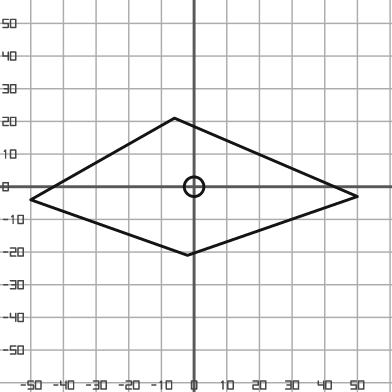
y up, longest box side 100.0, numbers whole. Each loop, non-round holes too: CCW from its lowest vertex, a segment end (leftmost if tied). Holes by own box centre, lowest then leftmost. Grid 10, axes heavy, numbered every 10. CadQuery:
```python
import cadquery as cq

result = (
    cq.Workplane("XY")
    .moveTo(-2.0, -21.0)
    .lineTo(50.0, -3.0)
    .lineTo(-6.0, 21.0)
    .lineTo(-50.0, -4.0)
    .close()
    .moveTo(0.0, 0.0)
    .circle(3.0)
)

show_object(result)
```